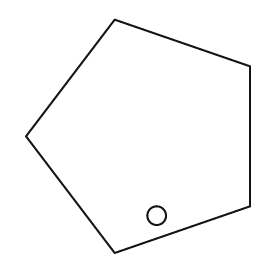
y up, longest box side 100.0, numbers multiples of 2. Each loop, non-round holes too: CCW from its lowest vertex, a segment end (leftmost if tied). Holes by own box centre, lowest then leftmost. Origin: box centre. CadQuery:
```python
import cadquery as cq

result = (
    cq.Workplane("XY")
    .moveTo(-10.0, -50.0)
    .lineTo(48.0, -30.0)
    .lineTo(48.0, 30.0)
    .lineTo(-10.0, 50.0)
    .lineTo(-48.0, 0.0)
    .close()
    .moveTo(8.0, -34.0)
    .circle(4.0)
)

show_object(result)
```